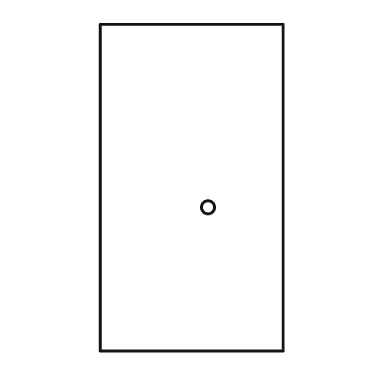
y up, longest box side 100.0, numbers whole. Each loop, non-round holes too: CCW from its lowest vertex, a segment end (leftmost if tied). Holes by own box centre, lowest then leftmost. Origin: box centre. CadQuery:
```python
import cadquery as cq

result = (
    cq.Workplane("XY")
    .moveTo(-28.0, -50.0)
    .lineTo(28.0, -50.0)
    .lineTo(28.0, 50.0)
    .lineTo(-28.0, 50.0)
    .close()
    .moveTo(5.0, -6.0)
    .circle(2.0)
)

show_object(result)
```